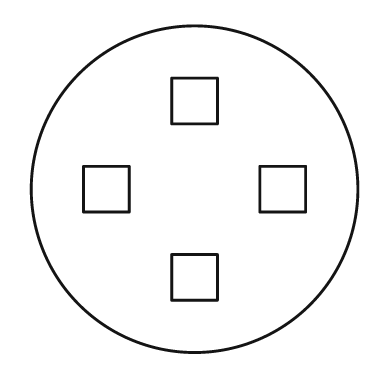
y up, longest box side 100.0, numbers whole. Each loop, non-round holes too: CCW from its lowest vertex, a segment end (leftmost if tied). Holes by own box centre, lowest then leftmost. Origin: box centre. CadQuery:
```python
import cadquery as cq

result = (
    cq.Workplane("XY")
    .moveTo(0.0, 0.0)
    .circle(50.0)
    .moveTo(-7.0, -34.0)
    .lineTo(7.0, -34.0)
    .lineTo(7.0, -20.0)
    .lineTo(-7.0, -20.0)
    .close()
    .moveTo(-34.0, -7.0)
    .lineTo(-20.0, -7.0)
    .lineTo(-20.0, 7.0)
    .lineTo(-34.0, 7.0)
    .close()
    .moveTo(20.0, -7.0)
    .lineTo(34.0, -7.0)
    .lineTo(34.0, 7.0)
    .lineTo(20.0, 7.0)
    .close()
    .moveTo(-7.0, 20.0)
    .lineTo(7.0, 20.0)
    .lineTo(7.0, 34.0)
    .lineTo(-7.0, 34.0)
    .close()
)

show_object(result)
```